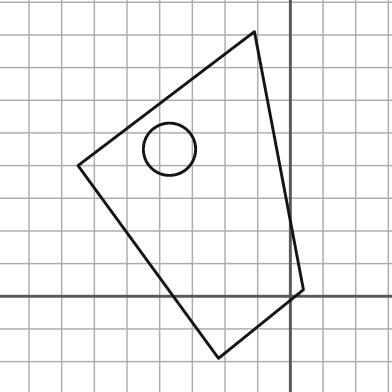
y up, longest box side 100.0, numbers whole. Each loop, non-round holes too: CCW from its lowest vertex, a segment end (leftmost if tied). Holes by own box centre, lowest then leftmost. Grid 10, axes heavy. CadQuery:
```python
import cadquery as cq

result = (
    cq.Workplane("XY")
    .moveTo(-22.0, -19.0)
    .lineTo(4.0, 2.0)
    .lineTo(-11.0, 81.0)
    .lineTo(-65.0, 40.0)
    .close()
    .moveTo(-37.0, 45.0)
    .circle(8.0)
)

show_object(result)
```